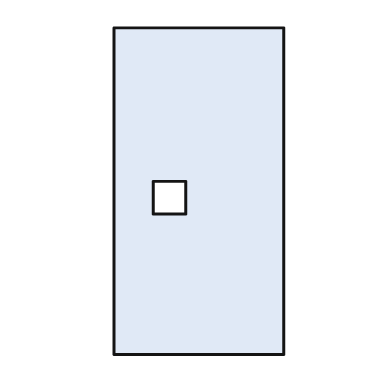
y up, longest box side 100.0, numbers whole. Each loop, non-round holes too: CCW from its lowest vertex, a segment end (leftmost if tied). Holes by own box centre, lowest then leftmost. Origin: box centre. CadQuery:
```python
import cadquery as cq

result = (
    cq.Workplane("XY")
    .moveTo(-26.0, -50.0)
    .lineTo(26.0, -50.0)
    .lineTo(26.0, 50.0)
    .lineTo(-26.0, 50.0)
    .close()
    .moveTo(-14.0, -7.0)
    .lineTo(-4.0, -7.0)
    .lineTo(-4.0, 3.0)
    .lineTo(-14.0, 3.0)
    .close()
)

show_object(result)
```